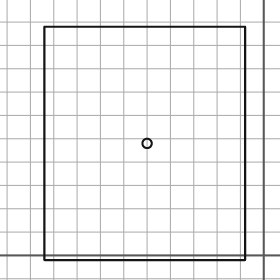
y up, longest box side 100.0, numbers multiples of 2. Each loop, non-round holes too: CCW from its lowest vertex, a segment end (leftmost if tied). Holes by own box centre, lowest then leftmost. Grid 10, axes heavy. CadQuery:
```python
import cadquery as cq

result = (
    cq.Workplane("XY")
    .moveTo(-94.0, -2.0)
    .lineTo(-8.0, -2.0)
    .lineTo(-8.0, 98.0)
    .lineTo(-94.0, 98.0)
    .close()
    .moveTo(-50.0, 48.0)
    .circle(2.0)
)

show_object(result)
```